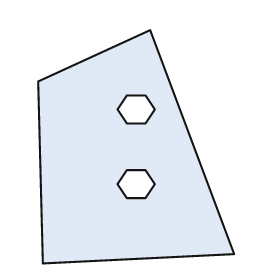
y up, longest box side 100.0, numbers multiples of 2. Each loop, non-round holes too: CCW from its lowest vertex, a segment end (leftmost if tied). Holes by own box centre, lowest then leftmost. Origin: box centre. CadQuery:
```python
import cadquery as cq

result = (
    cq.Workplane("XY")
    .moveTo(-40.0, -50.0)
    .lineTo(42.0, -46.0)
    .lineTo(6.0, 50.0)
    .lineTo(-42.0, 28.0)
    .close()
    .moveTo(-4.0, -22.0)
    .lineTo(4.0, -22.0)
    .lineTo(8.0, -16.0)
    .lineTo(4.0, -10.0)
    .lineTo(-4.0, -10.0)
    .lineTo(-8.0, -16.0)
    .close()
    .moveTo(-4.0, 10.0)
    .lineTo(4.0, 10.0)
    .lineTo(8.0, 16.0)
    .lineTo(4.0, 22.0)
    .lineTo(-4.0, 22.0)
    .lineTo(-8.0, 16.0)
    .close()
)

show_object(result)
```